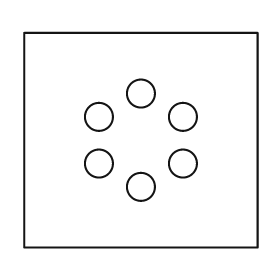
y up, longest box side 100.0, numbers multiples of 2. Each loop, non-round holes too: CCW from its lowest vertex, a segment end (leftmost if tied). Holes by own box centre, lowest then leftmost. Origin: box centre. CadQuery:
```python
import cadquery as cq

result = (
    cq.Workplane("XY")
    .moveTo(-50.0, -46.0)
    .lineTo(50.0, -46.0)
    .lineTo(50.0, 46.0)
    .lineTo(-50.0, 46.0)
    .close()
    .moveTo(0.0, -20.0)
    .circle(6.0)
    .moveTo(-18.0, -10.0)
    .circle(6.0)
    .moveTo(18.0, -10.0)
    .circle(6.0)
    .moveTo(-18.0, 10.0)
    .circle(6.0)
    .moveTo(18.0, 10.0)
    .circle(6.0)
    .moveTo(0.0, 20.0)
    .circle(6.0)
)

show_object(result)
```